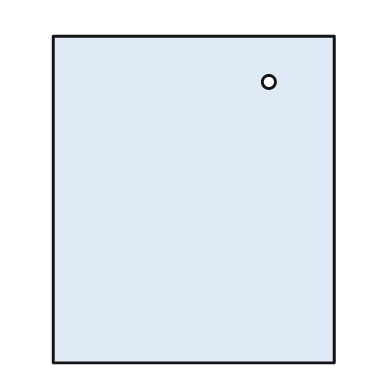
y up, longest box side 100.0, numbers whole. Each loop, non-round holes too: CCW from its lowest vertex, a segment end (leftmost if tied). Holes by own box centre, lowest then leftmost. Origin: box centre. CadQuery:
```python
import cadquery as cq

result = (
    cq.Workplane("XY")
    .moveTo(-43.0, -50.0)
    .lineTo(43.0, -50.0)
    .lineTo(43.0, 50.0)
    .lineTo(-43.0, 50.0)
    .close()
    .moveTo(23.0, 36.0)
    .circle(2.0)
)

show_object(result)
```